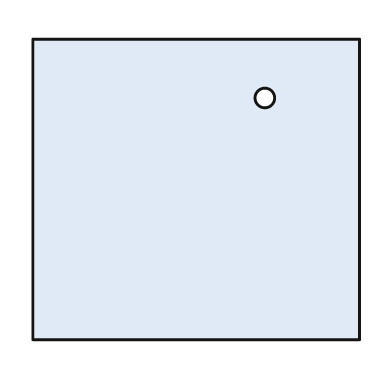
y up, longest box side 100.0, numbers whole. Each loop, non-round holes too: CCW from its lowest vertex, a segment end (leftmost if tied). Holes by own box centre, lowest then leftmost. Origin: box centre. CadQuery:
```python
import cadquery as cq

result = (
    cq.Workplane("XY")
    .moveTo(-50.0, -46.0)
    .lineTo(50.0, -46.0)
    .lineTo(50.0, 46.0)
    .lineTo(-50.0, 46.0)
    .close()
    .moveTo(21.0, 28.0)
    .circle(3.0)
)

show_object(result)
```